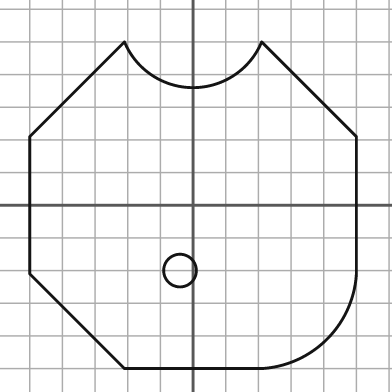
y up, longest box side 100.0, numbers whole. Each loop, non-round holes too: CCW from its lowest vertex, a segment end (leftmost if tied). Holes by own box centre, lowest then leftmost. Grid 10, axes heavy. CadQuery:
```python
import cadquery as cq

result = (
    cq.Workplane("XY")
    .moveTo(-21.0, -50.0)
    .lineTo(21.0, -50.0)
    .threePointArc((41.0, -41.0), (50.0, -21.0))
    .lineTo(50.0, 21.0)
    .lineTo(21.0, 50.0)
    .threePointArc((0.0, 36.0), (-21.0, 50.0))
    .lineTo(-50.0, 21.0)
    .lineTo(-50.0, -21.0)
    .close()
    .moveTo(-4.0, -20.0)
    .circle(5.0)
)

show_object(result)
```